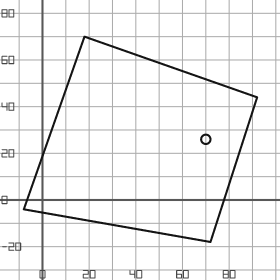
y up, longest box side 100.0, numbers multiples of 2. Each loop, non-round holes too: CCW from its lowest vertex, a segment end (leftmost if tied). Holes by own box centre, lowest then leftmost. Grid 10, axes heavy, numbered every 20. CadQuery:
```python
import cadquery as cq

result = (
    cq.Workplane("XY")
    .moveTo(72.0, -18.0)
    .lineTo(92.0, 44.0)
    .lineTo(18.0, 70.0)
    .lineTo(-8.0, -4.0)
    .close()
    .moveTo(70.0, 26.0)
    .circle(2.0)
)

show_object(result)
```